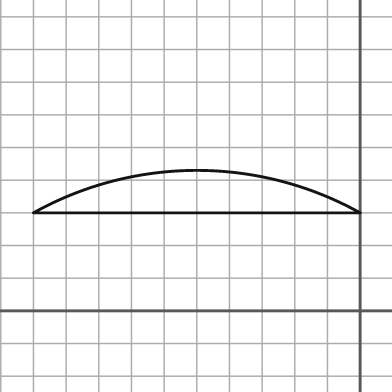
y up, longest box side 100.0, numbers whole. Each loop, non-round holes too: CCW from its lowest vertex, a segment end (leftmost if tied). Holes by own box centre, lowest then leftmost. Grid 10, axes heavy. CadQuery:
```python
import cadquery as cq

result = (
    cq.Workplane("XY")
    .moveTo(-100.0, 30.0)
    .lineTo(0.0, 30.0)
    .threePointArc((-50.0, 43.0), (-100.0, 30.0))
    .close()
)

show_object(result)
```